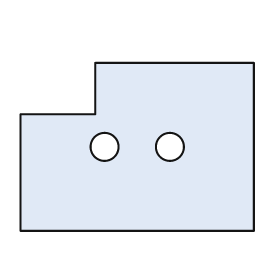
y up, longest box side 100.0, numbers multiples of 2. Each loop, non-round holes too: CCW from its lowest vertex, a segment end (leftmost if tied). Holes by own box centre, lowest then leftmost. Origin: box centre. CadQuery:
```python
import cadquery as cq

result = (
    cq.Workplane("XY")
    .moveTo(-50.0, -36.0)
    .lineTo(50.0, -36.0)
    .lineTo(50.0, 36.0)
    .lineTo(-18.0, 36.0)
    .lineTo(-18.0, 14.0)
    .lineTo(-50.0, 14.0)
    .close()
    .moveTo(-14.0, 0.0)
    .circle(6.0)
    .moveTo(14.0, 0.0)
    .circle(6.0)
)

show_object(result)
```